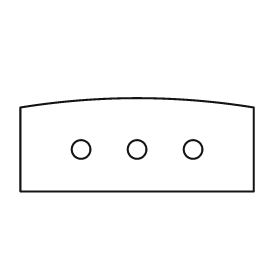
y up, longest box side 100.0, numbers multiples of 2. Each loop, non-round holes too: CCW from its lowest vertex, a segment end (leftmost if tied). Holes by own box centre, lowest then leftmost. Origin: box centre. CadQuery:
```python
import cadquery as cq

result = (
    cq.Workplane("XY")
    .moveTo(-50.0, -20.0)
    .lineTo(50.0, -20.0)
    .lineTo(50.0, 16.0)
    .threePointArc((0.0, 20.0), (-50.0, 16.0))
    .close()
    .moveTo(-24.0, -2.0)
    .circle(4.0)
    .moveTo(0.0, -2.0)
    .circle(4.0)
    .moveTo(24.0, -2.0)
    .circle(4.0)
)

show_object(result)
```